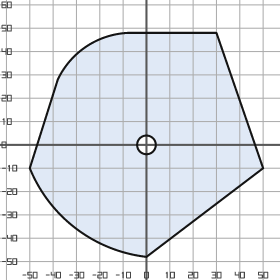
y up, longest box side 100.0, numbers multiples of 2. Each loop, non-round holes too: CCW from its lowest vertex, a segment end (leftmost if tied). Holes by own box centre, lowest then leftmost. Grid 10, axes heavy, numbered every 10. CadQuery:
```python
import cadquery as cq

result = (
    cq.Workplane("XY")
    .moveTo(0.0, -48.0)
    .lineTo(50.0, -10.0)
    .lineTo(30.0, 48.0)
    .lineTo(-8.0, 48.0)
    .threePointArc((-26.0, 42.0), (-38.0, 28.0))
    .lineTo(-50.0, -10.0)
    .threePointArc((-30.0, -36.0), (0.0, -48.0))
    .close()
    .moveTo(0.0, 0.0)
    .circle(4.0)
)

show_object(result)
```